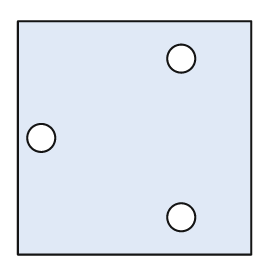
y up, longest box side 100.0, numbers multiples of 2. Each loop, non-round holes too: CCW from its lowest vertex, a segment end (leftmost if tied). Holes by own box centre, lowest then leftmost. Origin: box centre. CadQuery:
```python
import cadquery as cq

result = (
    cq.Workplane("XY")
    .moveTo(-50.0, -50.0)
    .lineTo(50.0, -50.0)
    .lineTo(50.0, 50.0)
    .lineTo(-50.0, 50.0)
    .close()
    .moveTo(20.0, -34.0)
    .circle(6.0)
    .moveTo(-40.0, 0.0)
    .circle(6.0)
    .moveTo(20.0, 34.0)
    .circle(6.0)
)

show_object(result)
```